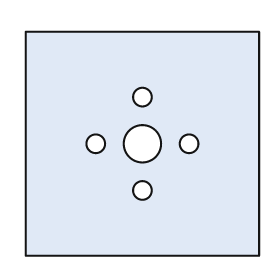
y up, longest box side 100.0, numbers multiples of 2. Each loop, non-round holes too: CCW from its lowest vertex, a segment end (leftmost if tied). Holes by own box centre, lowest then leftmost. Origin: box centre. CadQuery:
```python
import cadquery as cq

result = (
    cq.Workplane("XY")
    .moveTo(-50.0, -48.0)
    .lineTo(50.0, -48.0)
    .lineTo(50.0, 48.0)
    .lineTo(-50.0, 48.0)
    .close()
    .moveTo(0.0, -20.0)
    .circle(4.0)
    .moveTo(-20.0, 0.0)
    .circle(4.0)
    .moveTo(0.0, 0.0)
    .circle(8.0)
    .moveTo(20.0, 0.0)
    .circle(4.0)
    .moveTo(0.0, 20.0)
    .circle(4.0)
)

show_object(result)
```